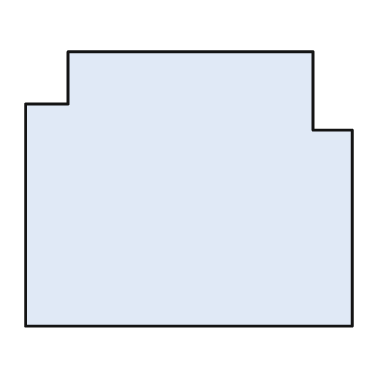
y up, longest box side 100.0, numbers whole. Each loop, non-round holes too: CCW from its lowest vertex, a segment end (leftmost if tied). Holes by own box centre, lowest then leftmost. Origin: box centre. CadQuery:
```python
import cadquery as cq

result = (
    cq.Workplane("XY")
    .moveTo(-50.0, -42.0)
    .lineTo(50.0, -42.0)
    .lineTo(50.0, 18.0)
    .lineTo(38.0, 18.0)
    .lineTo(38.0, 42.0)
    .lineTo(-37.0, 42.0)
    .lineTo(-37.0, 26.0)
    .lineTo(-50.0, 26.0)
    .close()
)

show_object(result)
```